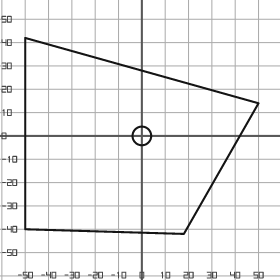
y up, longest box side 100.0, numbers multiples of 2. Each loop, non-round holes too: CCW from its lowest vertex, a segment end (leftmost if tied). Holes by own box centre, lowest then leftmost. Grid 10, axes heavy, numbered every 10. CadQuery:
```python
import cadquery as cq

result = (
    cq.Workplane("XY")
    .moveTo(18.0, -42.0)
    .lineTo(50.0, 14.0)
    .lineTo(-50.0, 42.0)
    .lineTo(-50.0, -40.0)
    .close()
    .moveTo(0.0, 0.0)
    .circle(4.0)
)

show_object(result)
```